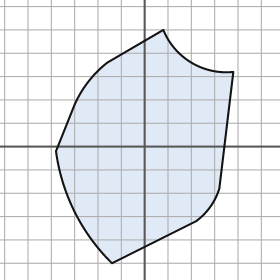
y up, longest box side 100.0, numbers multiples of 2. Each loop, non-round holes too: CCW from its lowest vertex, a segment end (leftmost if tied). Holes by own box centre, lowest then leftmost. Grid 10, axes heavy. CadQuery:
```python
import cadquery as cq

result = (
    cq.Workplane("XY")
    .moveTo(-14.0, -50.0)
    .lineTo(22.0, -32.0)
    .threePointArc((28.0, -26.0), (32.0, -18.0))
    .lineTo(38.0, 32.0)
    .threePointArc((20.0, 36.0), (8.0, 50.0))
    .lineTo(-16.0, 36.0)
    .threePointArc((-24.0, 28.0), (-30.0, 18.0))
    .lineTo(-38.0, -2.0)
    .threePointArc((-30.0, -28.0), (-14.0, -50.0))
    .close()
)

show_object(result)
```